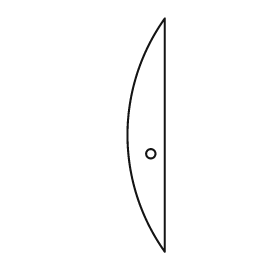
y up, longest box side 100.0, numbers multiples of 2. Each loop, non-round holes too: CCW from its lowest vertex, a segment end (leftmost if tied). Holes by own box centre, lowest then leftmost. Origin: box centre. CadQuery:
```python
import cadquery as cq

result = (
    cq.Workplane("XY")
    .moveTo(8.0, -50.0)
    .lineTo(8.0, 50.0)
    .threePointArc((-8.0, 0.0), (8.0, -50.0))
    .close()
    .moveTo(2.0, -8.0)
    .circle(2.0)
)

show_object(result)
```